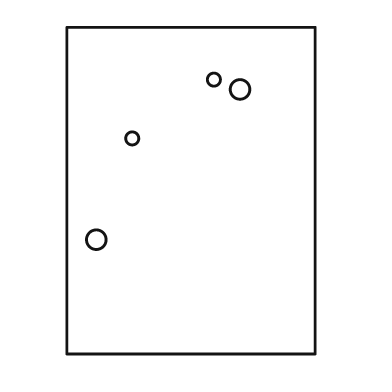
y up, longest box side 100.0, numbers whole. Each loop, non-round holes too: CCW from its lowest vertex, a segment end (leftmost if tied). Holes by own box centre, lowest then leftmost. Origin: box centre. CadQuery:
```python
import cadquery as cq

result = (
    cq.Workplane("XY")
    .moveTo(-38.0, -50.0)
    .lineTo(38.0, -50.0)
    .lineTo(38.0, 50.0)
    .lineTo(-38.0, 50.0)
    .close()
    .moveTo(-29.0, -15.0)
    .circle(3.0)
    .moveTo(-18.0, 16.0)
    .circle(2.0)
    .moveTo(15.0, 31.0)
    .circle(3.0)
    .moveTo(7.0, 34.0)
    .circle(2.0)
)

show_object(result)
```